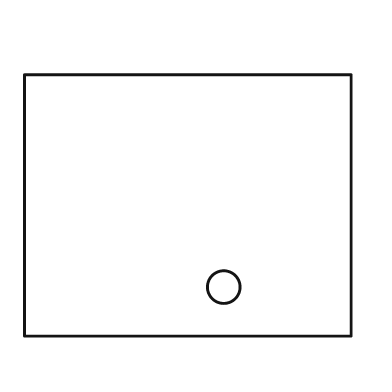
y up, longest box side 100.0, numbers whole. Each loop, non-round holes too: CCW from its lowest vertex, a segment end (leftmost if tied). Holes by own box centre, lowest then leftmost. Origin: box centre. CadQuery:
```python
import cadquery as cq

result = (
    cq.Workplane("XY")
    .moveTo(-50.0, -40.0)
    .lineTo(50.0, -40.0)
    .lineTo(50.0, 40.0)
    .lineTo(-50.0, 40.0)
    .close()
    .moveTo(11.0, -25.0)
    .circle(5.0)
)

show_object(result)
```